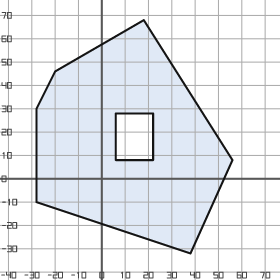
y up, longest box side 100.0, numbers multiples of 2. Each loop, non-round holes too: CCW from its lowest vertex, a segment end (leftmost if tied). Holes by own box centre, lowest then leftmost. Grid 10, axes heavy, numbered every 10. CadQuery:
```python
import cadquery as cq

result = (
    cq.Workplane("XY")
    .moveTo(38.0, -32.0)
    .lineTo(56.0, 8.0)
    .lineTo(18.0, 68.0)
    .lineTo(-20.0, 46.0)
    .lineTo(-28.0, 30.0)
    .lineTo(-28.0, -10.0)
    .close()
    .moveTo(6.0, 8.0)
    .lineTo(22.0, 8.0)
    .lineTo(22.0, 28.0)
    .lineTo(6.0, 28.0)
    .close()
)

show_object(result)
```